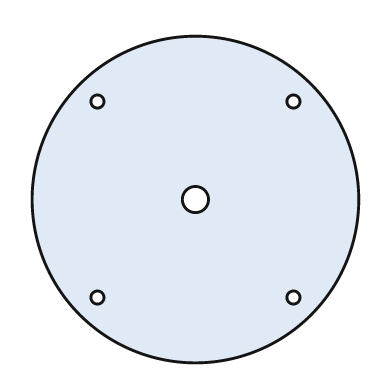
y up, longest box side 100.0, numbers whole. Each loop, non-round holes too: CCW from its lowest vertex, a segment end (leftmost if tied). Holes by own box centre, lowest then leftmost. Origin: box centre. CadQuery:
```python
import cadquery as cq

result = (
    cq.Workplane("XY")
    .moveTo(0.0, 0.0)
    .circle(50.0)
    .moveTo(-30.0, -30.0)
    .circle(2.0)
    .moveTo(30.0, -30.0)
    .circle(2.0)
    .moveTo(0.0, 0.0)
    .circle(4.0)
    .moveTo(-30.0, 30.0)
    .circle(2.0)
    .moveTo(30.0, 30.0)
    .circle(2.0)
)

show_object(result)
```